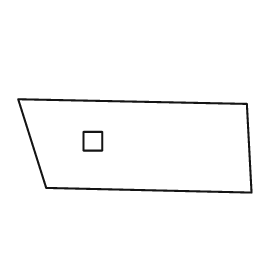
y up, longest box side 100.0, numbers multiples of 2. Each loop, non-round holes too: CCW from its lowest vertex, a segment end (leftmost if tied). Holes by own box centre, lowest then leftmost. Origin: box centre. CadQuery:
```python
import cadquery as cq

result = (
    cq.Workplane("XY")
    .moveTo(50.0, -20.0)
    .lineTo(48.0, 18.0)
    .lineTo(-50.0, 20.0)
    .lineTo(-38.0, -18.0)
    .close()
    .moveTo(-22.0, -2.0)
    .lineTo(-14.0, -2.0)
    .lineTo(-14.0, 6.0)
    .lineTo(-22.0, 6.0)
    .close()
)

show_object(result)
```